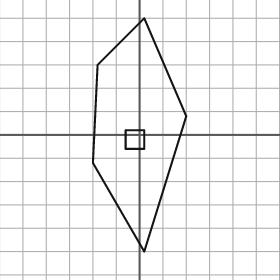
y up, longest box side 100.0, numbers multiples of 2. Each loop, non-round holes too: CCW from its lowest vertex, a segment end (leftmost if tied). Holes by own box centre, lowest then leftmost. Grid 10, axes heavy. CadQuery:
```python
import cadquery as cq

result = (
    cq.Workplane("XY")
    .moveTo(2.0, -50.0)
    .lineTo(20.0, 8.0)
    .lineTo(2.0, 50.0)
    .lineTo(-18.0, 30.0)
    .lineTo(-20.0, -12.0)
    .close()
    .moveTo(-6.0, -6.0)
    .lineTo(2.0, -6.0)
    .lineTo(2.0, 2.0)
    .lineTo(-6.0, 2.0)
    .close()
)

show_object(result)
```